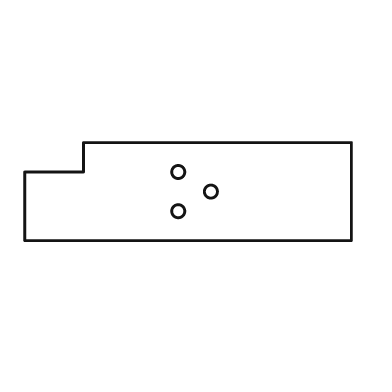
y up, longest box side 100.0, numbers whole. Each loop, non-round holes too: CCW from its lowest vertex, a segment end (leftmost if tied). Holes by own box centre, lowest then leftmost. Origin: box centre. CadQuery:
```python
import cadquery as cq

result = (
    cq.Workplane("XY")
    .moveTo(-50.0, -15.0)
    .lineTo(50.0, -15.0)
    .lineTo(50.0, 15.0)
    .lineTo(-32.0, 15.0)
    .lineTo(-32.0, 6.0)
    .lineTo(-50.0, 6.0)
    .close()
    .moveTo(-3.0, -6.0)
    .circle(2.0)
    .moveTo(7.0, 0.0)
    .circle(2.0)
    .moveTo(-3.0, 6.0)
    .circle(2.0)
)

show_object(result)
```